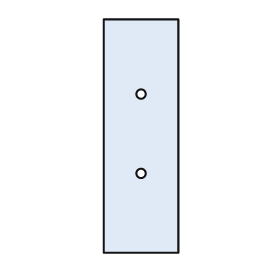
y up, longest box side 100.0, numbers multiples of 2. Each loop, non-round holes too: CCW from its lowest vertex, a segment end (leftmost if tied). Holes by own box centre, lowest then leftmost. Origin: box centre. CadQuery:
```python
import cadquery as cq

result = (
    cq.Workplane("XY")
    .moveTo(-16.0, -50.0)
    .lineTo(16.0, -50.0)
    .lineTo(16.0, 50.0)
    .lineTo(-16.0, 50.0)
    .close()
    .moveTo(0.0, -16.0)
    .circle(2.0)
    .moveTo(0.0, 18.0)
    .circle(2.0)
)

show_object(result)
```